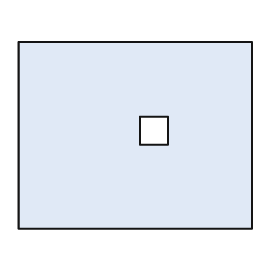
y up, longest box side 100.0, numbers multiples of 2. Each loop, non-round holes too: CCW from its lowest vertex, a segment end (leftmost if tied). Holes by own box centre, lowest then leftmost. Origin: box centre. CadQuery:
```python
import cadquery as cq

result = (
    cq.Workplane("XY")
    .moveTo(-50.0, -40.0)
    .lineTo(50.0, -40.0)
    .lineTo(50.0, 40.0)
    .lineTo(-50.0, 40.0)
    .close()
    .moveTo(2.0, -4.0)
    .lineTo(14.0, -4.0)
    .lineTo(14.0, 8.0)
    .lineTo(2.0, 8.0)
    .close()
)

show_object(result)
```